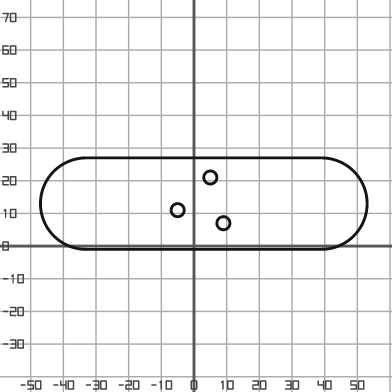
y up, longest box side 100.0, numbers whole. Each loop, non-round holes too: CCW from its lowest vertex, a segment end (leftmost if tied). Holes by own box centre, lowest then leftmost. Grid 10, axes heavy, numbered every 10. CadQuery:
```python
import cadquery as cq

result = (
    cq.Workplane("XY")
    .moveTo(-33.0, -1.0)
    .lineTo(39.0, -1.0)
    .threePointArc((53.0, 13.0), (39.0, 27.0))
    .lineTo(-33.0, 27.0)
    .threePointArc((-47.0, 13.0), (-33.0, -1.0))
    .close()
    .moveTo(9.0, 7.0)
    .circle(2.0)
    .moveTo(-5.0, 11.0)
    .circle(2.0)
    .moveTo(5.0, 21.0)
    .circle(2.0)
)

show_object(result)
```